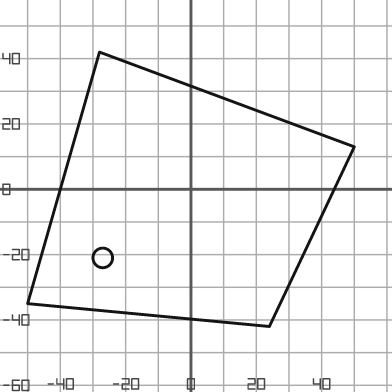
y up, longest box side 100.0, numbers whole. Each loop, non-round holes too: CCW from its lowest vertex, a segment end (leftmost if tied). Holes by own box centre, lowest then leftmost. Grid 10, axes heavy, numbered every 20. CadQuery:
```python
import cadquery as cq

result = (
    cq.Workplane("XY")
    .moveTo(24.0, -42.0)
    .lineTo(50.0, 13.0)
    .lineTo(-28.0, 42.0)
    .lineTo(-50.0, -35.0)
    .close()
    .moveTo(-27.0, -21.0)
    .circle(3.0)
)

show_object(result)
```